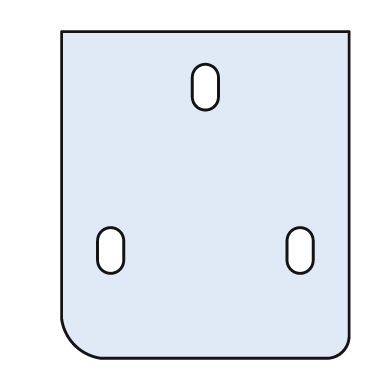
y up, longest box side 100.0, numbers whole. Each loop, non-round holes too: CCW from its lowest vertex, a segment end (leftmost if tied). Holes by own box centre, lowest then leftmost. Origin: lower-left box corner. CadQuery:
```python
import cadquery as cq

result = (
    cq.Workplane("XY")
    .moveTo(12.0, 0.0)
    .lineTo(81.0, 0.0)
    .threePointArc((86.0, 2.0), (88.0, 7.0))
    .lineTo(88.0, 100.0)
    .lineTo(0.0, 100.0)
    .lineTo(0.0, 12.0)
    .threePointArc((4.0, 4.0), (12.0, 0.0))
    .close()
    .moveTo(11.0, 30.0)
    .threePointArc((15.0, 26.0), (19.0, 30.0))
    .lineTo(19.0, 36.0)
    .threePointArc((15.0, 40.0), (11.0, 36.0))
    .close()
    .moveTo(69.0, 30.0)
    .threePointArc((73.0, 26.0), (77.0, 30.0))
    .lineTo(77.0, 36.0)
    .threePointArc((73.0, 40.0), (69.0, 36.0))
    .close()
    .moveTo(40.0, 80.0)
    .threePointArc((44.0, 76.0), (48.0, 80.0))
    .lineTo(48.0, 86.0)
    .threePointArc((44.0, 90.0), (40.0, 86.0))
    .close()
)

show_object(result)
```